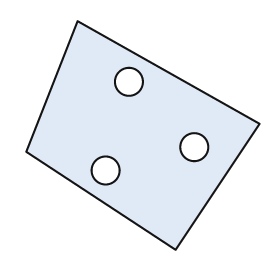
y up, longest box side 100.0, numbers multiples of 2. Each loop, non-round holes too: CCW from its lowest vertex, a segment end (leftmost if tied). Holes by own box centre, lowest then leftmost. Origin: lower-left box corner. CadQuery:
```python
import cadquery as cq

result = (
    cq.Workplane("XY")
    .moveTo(64.0, 0.0)
    .lineTo(100.0, 54.0)
    .lineTo(22.0, 98.0)
    .lineTo(0.0, 42.0)
    .close()
    .moveTo(34.0, 34.0)
    .circle(6.0)
    .moveTo(72.0, 44.0)
    .circle(6.0)
    .moveTo(44.0, 72.0)
    .circle(6.0)
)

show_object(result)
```